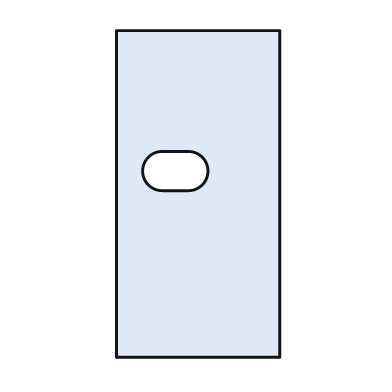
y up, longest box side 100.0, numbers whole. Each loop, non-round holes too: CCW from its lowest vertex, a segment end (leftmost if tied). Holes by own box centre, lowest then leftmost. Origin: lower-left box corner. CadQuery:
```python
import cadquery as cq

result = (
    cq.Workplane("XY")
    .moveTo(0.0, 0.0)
    .lineTo(50.0, 0.0)
    .lineTo(50.0, 100.0)
    .lineTo(0.0, 100.0)
    .close()
    .moveTo(14.0, 51.0)
    .lineTo(22.0, 51.0)
    .threePointArc((28.0, 57.0), (22.0, 63.0))
    .lineTo(14.0, 63.0)
    .threePointArc((8.0, 57.0), (14.0, 51.0))
    .close()
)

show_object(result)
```